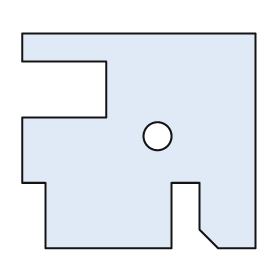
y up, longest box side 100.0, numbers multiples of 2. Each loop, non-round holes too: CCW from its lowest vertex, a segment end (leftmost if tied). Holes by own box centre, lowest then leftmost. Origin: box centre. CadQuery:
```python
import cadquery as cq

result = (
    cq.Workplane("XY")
    .moveTo(-40.0, -46.0)
    .lineTo(14.0, -46.0)
    .lineTo(14.0, -18.0)
    .lineTo(26.0, -18.0)
    .lineTo(26.0, -38.0)
    .lineTo(34.0, -46.0)
    .lineTo(50.0, -46.0)
    .lineTo(50.0, 46.0)
    .lineTo(-50.0, 46.0)
    .lineTo(-50.0, 34.0)
    .lineTo(-14.0, 34.0)
    .lineTo(-14.0, 10.0)
    .lineTo(-50.0, 10.0)
    .lineTo(-50.0, -18.0)
    .lineTo(-40.0, -18.0)
    .close()
    .moveTo(8.0, 2.0)
    .circle(6.0)
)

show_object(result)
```